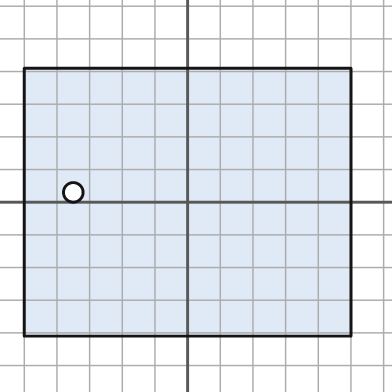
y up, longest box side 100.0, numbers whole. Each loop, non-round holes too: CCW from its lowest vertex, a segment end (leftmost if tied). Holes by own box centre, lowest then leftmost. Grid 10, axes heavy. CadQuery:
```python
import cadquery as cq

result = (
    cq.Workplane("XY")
    .moveTo(-50.0, -41.0)
    .lineTo(50.0, -41.0)
    .lineTo(50.0, 41.0)
    .lineTo(-50.0, 41.0)
    .close()
    .moveTo(-35.0, 3.0)
    .circle(3.0)
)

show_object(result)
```